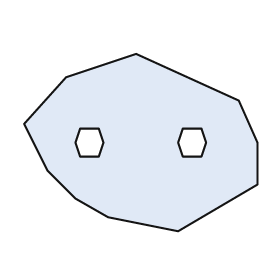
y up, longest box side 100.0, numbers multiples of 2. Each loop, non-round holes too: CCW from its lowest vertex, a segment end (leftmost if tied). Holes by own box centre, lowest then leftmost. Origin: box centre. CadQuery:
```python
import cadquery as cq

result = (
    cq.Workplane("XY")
    .moveTo(16.0, -38.0)
    .lineTo(50.0, -18.0)
    .lineTo(50.0, 0.0)
    .lineTo(42.0, 18.0)
    .lineTo(-2.0, 38.0)
    .lineTo(-32.0, 28.0)
    .lineTo(-50.0, 8.0)
    .lineTo(-40.0, -12.0)
    .lineTo(-28.0, -24.0)
    .lineTo(-14.0, -32.0)
    .close()
    .moveTo(-26.0, -6.0)
    .lineTo(-18.0, -6.0)
    .lineTo(-16.0, 0.0)
    .lineTo(-18.0, 6.0)
    .lineTo(-26.0, 6.0)
    .lineTo(-28.0, 0.0)
    .close()
    .moveTo(18.0, -6.0)
    .lineTo(26.0, -6.0)
    .lineTo(28.0, 0.0)
    .lineTo(26.0, 6.0)
    .lineTo(18.0, 6.0)
    .lineTo(16.0, 0.0)
    .close()
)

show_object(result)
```